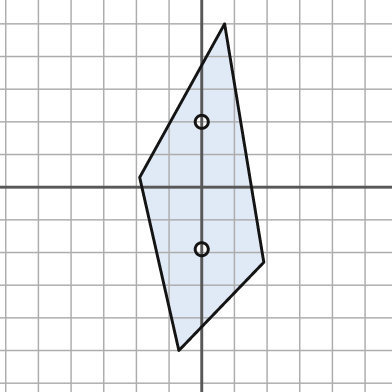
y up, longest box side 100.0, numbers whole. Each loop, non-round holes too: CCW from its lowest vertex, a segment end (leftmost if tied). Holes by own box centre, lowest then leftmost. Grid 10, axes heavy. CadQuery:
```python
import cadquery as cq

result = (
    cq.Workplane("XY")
    .moveTo(-7.0, -50.0)
    .lineTo(19.0, -23.0)
    .lineTo(7.0, 50.0)
    .lineTo(-19.0, 3.0)
    .close()
    .moveTo(0.0, -19.0)
    .circle(2.0)
    .moveTo(0.0, 20.0)
    .circle(2.0)
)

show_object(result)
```